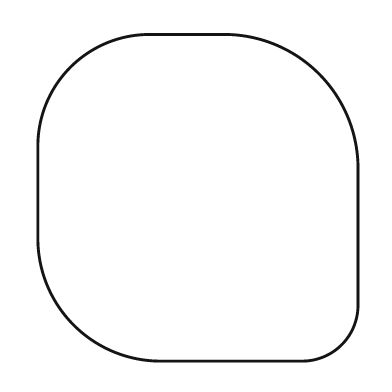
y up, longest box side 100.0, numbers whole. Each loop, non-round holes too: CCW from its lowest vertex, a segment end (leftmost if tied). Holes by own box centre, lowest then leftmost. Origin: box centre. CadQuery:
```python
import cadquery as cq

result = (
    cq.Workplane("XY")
    .moveTo(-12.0, -50.0)
    .lineTo(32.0, -50.0)
    .threePointArc((44.0, -45.0), (49.0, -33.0))
    .lineTo(49.0, 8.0)
    .threePointArc((37.0, 38.0), (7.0, 50.0))
    .lineTo(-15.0, 50.0)
    .threePointArc((-39.0, 40.0), (-49.0, 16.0))
    .lineTo(-49.0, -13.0)
    .threePointArc((-38.0, -39.0), (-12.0, -50.0))
    .close()
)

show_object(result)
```